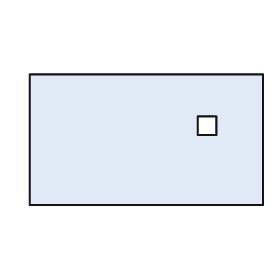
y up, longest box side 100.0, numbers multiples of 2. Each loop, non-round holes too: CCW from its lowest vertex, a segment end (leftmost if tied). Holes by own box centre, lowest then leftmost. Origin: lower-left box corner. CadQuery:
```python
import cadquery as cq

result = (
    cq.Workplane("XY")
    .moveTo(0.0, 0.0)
    .lineTo(100.0, 0.0)
    .lineTo(100.0, 56.0)
    .lineTo(0.0, 56.0)
    .close()
    .moveTo(72.0, 30.0)
    .lineTo(80.0, 30.0)
    .lineTo(80.0, 38.0)
    .lineTo(72.0, 38.0)
    .close()
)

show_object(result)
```